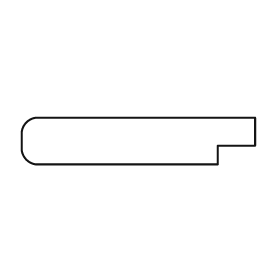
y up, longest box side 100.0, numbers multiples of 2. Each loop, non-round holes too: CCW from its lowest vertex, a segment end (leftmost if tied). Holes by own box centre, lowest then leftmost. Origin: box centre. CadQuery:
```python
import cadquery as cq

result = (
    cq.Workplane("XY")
    .moveTo(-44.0, -10.0)
    .lineTo(34.0, -10.0)
    .lineTo(34.0, -2.0)
    .lineTo(50.0, -2.0)
    .lineTo(50.0, 10.0)
    .lineTo(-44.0, 10.0)
    .threePointArc((-48.0, 8.0), (-50.0, 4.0))
    .lineTo(-50.0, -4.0)
    .threePointArc((-48.0, -8.0), (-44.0, -10.0))
    .close()
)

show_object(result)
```